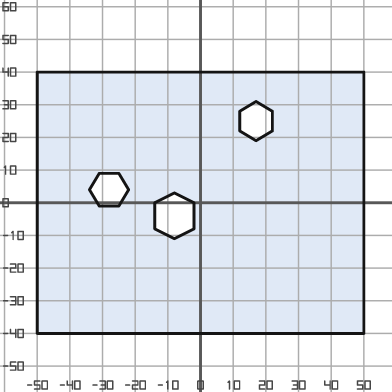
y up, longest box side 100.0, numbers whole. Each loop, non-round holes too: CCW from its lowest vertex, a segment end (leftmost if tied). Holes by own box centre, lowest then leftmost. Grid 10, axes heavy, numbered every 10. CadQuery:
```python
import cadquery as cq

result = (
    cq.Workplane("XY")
    .moveTo(-50.0, -40.0)
    .lineTo(50.0, -40.0)
    .lineTo(50.0, 40.0)
    .lineTo(-50.0, 40.0)
    .close()
    .moveTo(-8.0, -11.0)
    .lineTo(-2.0, -8.0)
    .lineTo(-2.0, 0.0)
    .lineTo(-8.0, 3.0)
    .lineTo(-14.0, 0.0)
    .lineTo(-14.0, -8.0)
    .close()
    .moveTo(-31.0, -1.0)
    .lineTo(-25.0, -1.0)
    .lineTo(-22.0, 4.0)
    .lineTo(-25.0, 9.0)
    .lineTo(-31.0, 9.0)
    .lineTo(-34.0, 4.0)
    .close()
    .moveTo(17.0, 19.0)
    .lineTo(22.0, 22.0)
    .lineTo(22.0, 28.0)
    .lineTo(17.0, 31.0)
    .lineTo(12.0, 28.0)
    .lineTo(12.0, 22.0)
    .close()
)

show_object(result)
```